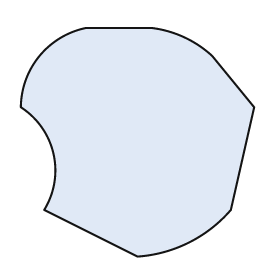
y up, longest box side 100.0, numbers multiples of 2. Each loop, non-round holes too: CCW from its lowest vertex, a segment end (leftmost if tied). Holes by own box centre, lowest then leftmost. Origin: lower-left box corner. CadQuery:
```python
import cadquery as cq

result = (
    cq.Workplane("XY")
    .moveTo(50.0, 0.0)
    .threePointArc((72.0, 6.0), (90.0, 20.0))
    .lineTo(100.0, 64.0)
    .lineTo(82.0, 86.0)
    .threePointArc((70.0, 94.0), (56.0, 98.0))
    .lineTo(28.0, 98.0)
    .threePointArc((8.0, 86.0), (0.0, 64.0))
    .threePointArc((14.0, 44.0), (10.0, 20.0))
    .close()
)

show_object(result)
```